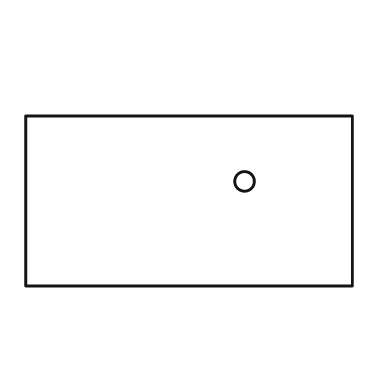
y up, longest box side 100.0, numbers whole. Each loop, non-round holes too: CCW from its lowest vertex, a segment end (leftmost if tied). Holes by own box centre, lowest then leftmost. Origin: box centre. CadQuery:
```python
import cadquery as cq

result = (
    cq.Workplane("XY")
    .moveTo(-50.0, -26.0)
    .lineTo(50.0, -26.0)
    .lineTo(50.0, 26.0)
    .lineTo(-50.0, 26.0)
    .close()
    .moveTo(17.0, 6.0)
    .circle(3.0)
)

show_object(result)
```